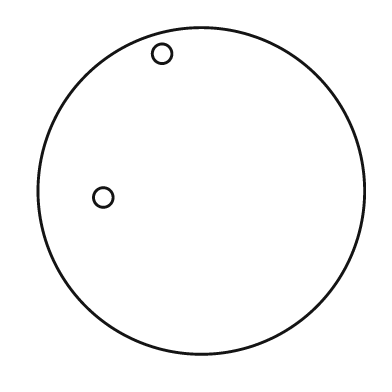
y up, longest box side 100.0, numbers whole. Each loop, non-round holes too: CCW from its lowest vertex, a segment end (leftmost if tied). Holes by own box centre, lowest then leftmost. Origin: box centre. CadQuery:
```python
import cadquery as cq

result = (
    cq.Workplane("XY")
    .moveTo(0.0, 0.0)
    .circle(50.0)
    .moveTo(-30.0, -2.0)
    .circle(3.0)
    .moveTo(-12.0, 42.0)
    .circle(3.0)
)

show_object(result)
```